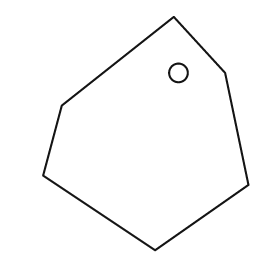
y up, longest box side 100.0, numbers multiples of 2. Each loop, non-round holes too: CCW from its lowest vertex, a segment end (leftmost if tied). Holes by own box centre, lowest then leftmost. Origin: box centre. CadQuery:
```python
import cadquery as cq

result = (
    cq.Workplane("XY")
    .moveTo(4.0, -50.0)
    .lineTo(44.0, -22.0)
    .lineTo(34.0, 26.0)
    .lineTo(12.0, 50.0)
    .lineTo(-36.0, 12.0)
    .lineTo(-44.0, -18.0)
    .close()
    .moveTo(14.0, 26.0)
    .circle(4.0)
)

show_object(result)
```